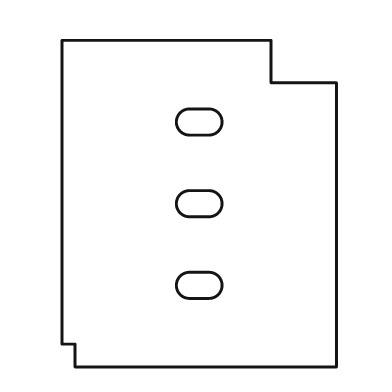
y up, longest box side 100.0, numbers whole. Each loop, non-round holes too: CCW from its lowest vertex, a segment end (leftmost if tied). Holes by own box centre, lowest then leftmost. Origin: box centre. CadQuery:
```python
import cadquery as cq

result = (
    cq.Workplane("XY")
    .moveTo(-38.0, -50.0)
    .lineTo(42.0, -50.0)
    .lineTo(42.0, 37.0)
    .lineTo(22.0, 37.0)
    .lineTo(22.0, 50.0)
    .lineTo(-42.0, 50.0)
    .lineTo(-42.0, -43.0)
    .lineTo(-38.0, -43.0)
    .close()
    .moveTo(-3.0, -29.0)
    .lineTo(3.0, -29.0)
    .threePointArc((7.0, -25.0), (3.0, -21.0))
    .lineTo(-3.0, -21.0)
    .threePointArc((-7.0, -25.0), (-3.0, -29.0))
    .close()
    .moveTo(-3.0, -4.0)
    .lineTo(3.0, -4.0)
    .threePointArc((7.0, 0.0), (3.0, 4.0))
    .lineTo(-3.0, 4.0)
    .threePointArc((-7.0, 0.0), (-3.0, -4.0))
    .close()
    .moveTo(-3.0, 21.0)
    .lineTo(3.0, 21.0)
    .threePointArc((7.0, 25.0), (3.0, 29.0))
    .lineTo(-3.0, 29.0)
    .threePointArc((-7.0, 25.0), (-3.0, 21.0))
    .close()
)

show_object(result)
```